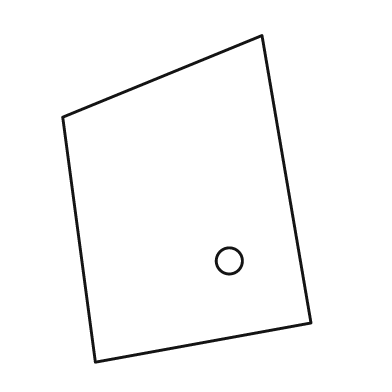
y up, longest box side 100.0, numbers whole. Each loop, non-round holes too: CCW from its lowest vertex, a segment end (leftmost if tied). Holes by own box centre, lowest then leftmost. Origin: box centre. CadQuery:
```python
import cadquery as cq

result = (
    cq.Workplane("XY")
    .moveTo(-28.0, -50.0)
    .lineTo(38.0, -38.0)
    .lineTo(23.0, 50.0)
    .lineTo(-38.0, 25.0)
    .close()
    .moveTo(13.0, -19.0)
    .circle(4.0)
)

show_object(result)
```